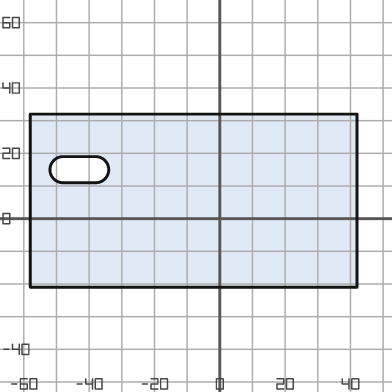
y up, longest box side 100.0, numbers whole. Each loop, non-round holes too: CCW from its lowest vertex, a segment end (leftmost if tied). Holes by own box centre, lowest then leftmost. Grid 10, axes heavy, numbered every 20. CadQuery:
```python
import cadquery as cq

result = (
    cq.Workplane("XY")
    .moveTo(-58.0, -21.0)
    .lineTo(42.0, -21.0)
    .lineTo(42.0, 32.0)
    .lineTo(-58.0, 32.0)
    .close()
    .moveTo(-48.0, 11.0)
    .lineTo(-38.0, 11.0)
    .threePointArc((-34.0, 15.0), (-38.0, 19.0))
    .lineTo(-48.0, 19.0)
    .threePointArc((-52.0, 15.0), (-48.0, 11.0))
    .close()
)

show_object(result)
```